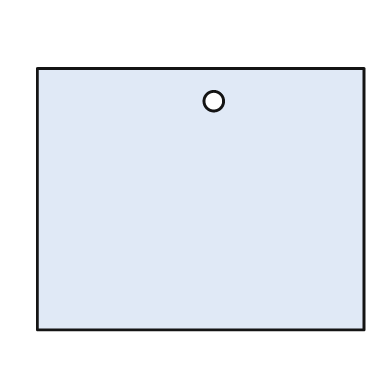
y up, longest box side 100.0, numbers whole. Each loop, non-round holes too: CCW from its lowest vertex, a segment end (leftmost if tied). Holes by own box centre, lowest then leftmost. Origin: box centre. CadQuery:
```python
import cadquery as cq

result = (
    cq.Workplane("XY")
    .moveTo(-50.0, -40.0)
    .lineTo(50.0, -40.0)
    .lineTo(50.0, 40.0)
    .lineTo(-50.0, 40.0)
    .close()
    .moveTo(4.0, 30.0)
    .circle(3.0)
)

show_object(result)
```